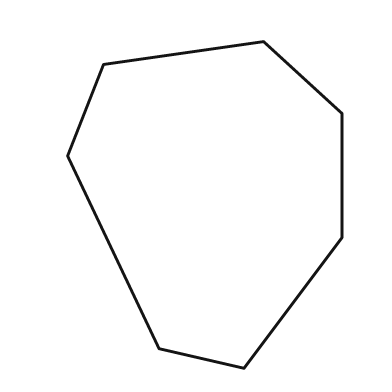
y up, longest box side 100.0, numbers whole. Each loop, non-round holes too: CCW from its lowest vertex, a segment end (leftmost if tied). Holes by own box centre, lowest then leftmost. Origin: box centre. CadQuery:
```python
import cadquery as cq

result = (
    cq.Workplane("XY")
    .moveTo(12.0, -50.0)
    .lineTo(42.0, -10.0)
    .lineTo(42.0, 28.0)
    .lineTo(18.0, 50.0)
    .lineTo(-31.0, 43.0)
    .lineTo(-42.0, 15.0)
    .lineTo(-14.0, -44.0)
    .close()
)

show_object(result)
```